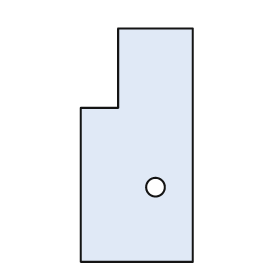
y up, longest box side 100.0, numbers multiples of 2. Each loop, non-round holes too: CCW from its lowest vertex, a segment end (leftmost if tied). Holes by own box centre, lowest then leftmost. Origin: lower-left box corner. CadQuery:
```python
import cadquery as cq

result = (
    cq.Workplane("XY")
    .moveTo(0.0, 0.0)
    .lineTo(48.0, 0.0)
    .lineTo(48.0, 100.0)
    .lineTo(16.0, 100.0)
    .lineTo(16.0, 66.0)
    .lineTo(0.0, 66.0)
    .close()
    .moveTo(32.0, 32.0)
    .circle(4.0)
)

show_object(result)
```